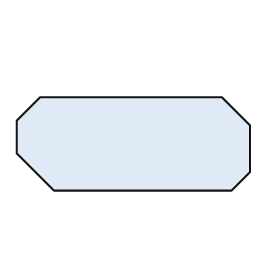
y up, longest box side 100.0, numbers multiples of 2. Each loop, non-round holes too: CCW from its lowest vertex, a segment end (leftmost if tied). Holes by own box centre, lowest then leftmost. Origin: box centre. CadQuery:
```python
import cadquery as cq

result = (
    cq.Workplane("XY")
    .moveTo(-34.0, -20.0)
    .lineTo(42.0, -20.0)
    .lineTo(50.0, -12.0)
    .lineTo(50.0, 8.0)
    .lineTo(38.0, 20.0)
    .lineTo(-40.0, 20.0)
    .lineTo(-50.0, 10.0)
    .lineTo(-50.0, -4.0)
    .close()
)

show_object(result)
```